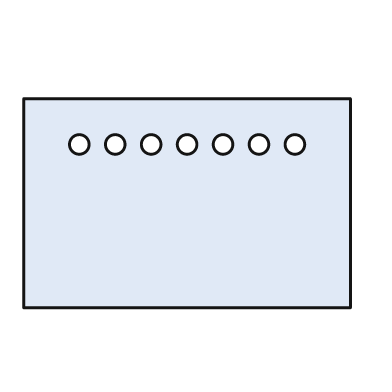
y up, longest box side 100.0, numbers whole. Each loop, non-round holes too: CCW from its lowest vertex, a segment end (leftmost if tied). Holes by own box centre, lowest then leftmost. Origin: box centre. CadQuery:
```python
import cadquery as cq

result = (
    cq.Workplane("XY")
    .moveTo(-50.0, -32.0)
    .lineTo(50.0, -32.0)
    .lineTo(50.0, 32.0)
    .lineTo(-50.0, 32.0)
    .close()
    .moveTo(-33.0, 18.0)
    .circle(3.0)
    .moveTo(-22.0, 18.0)
    .circle(3.0)
    .moveTo(-11.0, 18.0)
    .circle(3.0)
    .moveTo(0.0, 18.0)
    .circle(3.0)
    .moveTo(11.0, 18.0)
    .circle(3.0)
    .moveTo(22.0, 18.0)
    .circle(3.0)
    .moveTo(33.0, 18.0)
    .circle(3.0)
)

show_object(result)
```